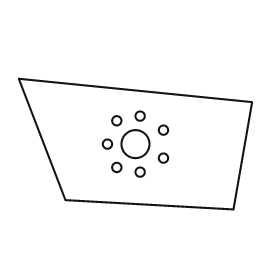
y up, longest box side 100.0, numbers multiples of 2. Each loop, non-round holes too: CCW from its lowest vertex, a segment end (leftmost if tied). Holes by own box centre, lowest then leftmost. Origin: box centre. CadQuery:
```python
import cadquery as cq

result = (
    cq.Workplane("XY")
    .moveTo(42.0, -28.0)
    .lineTo(50.0, 18.0)
    .lineTo(-50.0, 28.0)
    .lineTo(-30.0, -24.0)
    .close()
    .moveTo(2.0, -12.0)
    .circle(2.0)
    .moveTo(-8.0, -10.0)
    .circle(2.0)
    .moveTo(12.0, -6.0)
    .circle(2.0)
    .moveTo(-12.0, 0.0)
    .circle(2.0)
    .moveTo(0.0, 0.0)
    .circle(6.0)
    .moveTo(12.0, 6.0)
    .circle(2.0)
    .moveTo(-8.0, 10.0)
    .circle(2.0)
    .moveTo(2.0, 12.0)
    .circle(2.0)
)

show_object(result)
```